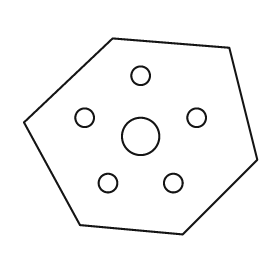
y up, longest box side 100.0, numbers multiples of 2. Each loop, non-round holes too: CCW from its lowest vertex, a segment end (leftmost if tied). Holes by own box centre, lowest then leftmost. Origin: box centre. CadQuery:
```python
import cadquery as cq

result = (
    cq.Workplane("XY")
    .moveTo(18.0, -42.0)
    .lineTo(50.0, -10.0)
    .lineTo(38.0, 38.0)
    .lineTo(-12.0, 42.0)
    .lineTo(-50.0, 6.0)
    .lineTo(-26.0, -38.0)
    .close()
    .moveTo(-14.0, -20.0)
    .circle(4.0)
    .moveTo(14.0, -20.0)
    .circle(4.0)
    .moveTo(0.0, 0.0)
    .circle(8.0)
    .moveTo(-24.0, 8.0)
    .circle(4.0)
    .moveTo(24.0, 8.0)
    .circle(4.0)
    .moveTo(0.0, 26.0)
    .circle(4.0)
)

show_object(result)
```